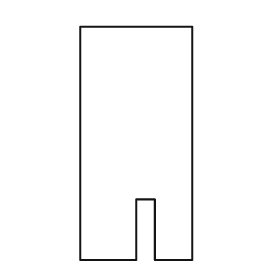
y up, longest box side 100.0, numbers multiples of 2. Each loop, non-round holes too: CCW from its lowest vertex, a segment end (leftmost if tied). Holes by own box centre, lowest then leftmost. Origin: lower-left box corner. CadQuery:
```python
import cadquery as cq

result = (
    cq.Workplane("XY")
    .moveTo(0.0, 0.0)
    .lineTo(24.0, 0.0)
    .lineTo(24.0, 26.0)
    .lineTo(32.0, 26.0)
    .lineTo(32.0, 0.0)
    .lineTo(48.0, 0.0)
    .lineTo(48.0, 100.0)
    .lineTo(0.0, 100.0)
    .close()
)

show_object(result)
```